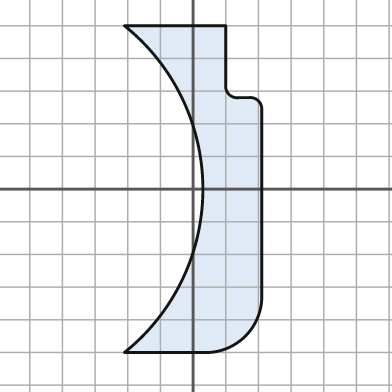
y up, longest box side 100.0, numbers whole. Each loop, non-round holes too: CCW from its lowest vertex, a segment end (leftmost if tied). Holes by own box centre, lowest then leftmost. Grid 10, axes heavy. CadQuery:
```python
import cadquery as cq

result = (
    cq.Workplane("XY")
    .moveTo(-21.0, -50.0)
    .lineTo(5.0, -50.0)
    .threePointArc((16.0, -45.0), (21.0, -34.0))
    .lineTo(21.0, 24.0)
    .threePointArc((20.0, 27.0), (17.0, 28.0))
    .lineTo(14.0, 28.0)
    .threePointArc((11.0, 29.0), (10.0, 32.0))
    .lineTo(10.0, 50.0)
    .lineTo(-21.0, 50.0)
    .threePointArc((3.0, 0.0), (-21.0, -50.0))
    .close()
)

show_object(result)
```